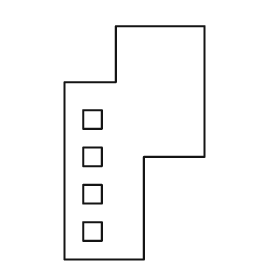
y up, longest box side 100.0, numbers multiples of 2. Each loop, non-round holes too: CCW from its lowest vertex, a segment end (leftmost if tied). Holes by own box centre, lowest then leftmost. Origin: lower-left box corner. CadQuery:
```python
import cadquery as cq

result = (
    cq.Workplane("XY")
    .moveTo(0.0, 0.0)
    .lineTo(34.0, 0.0)
    .lineTo(34.0, 44.0)
    .lineTo(60.0, 44.0)
    .lineTo(60.0, 100.0)
    .lineTo(22.0, 100.0)
    .lineTo(22.0, 76.0)
    .lineTo(0.0, 76.0)
    .close()
    .moveTo(8.0, 8.0)
    .lineTo(16.0, 8.0)
    .lineTo(16.0, 16.0)
    .lineTo(8.0, 16.0)
    .close()
    .moveTo(8.0, 24.0)
    .lineTo(16.0, 24.0)
    .lineTo(16.0, 32.0)
    .lineTo(8.0, 32.0)
    .close()
    .moveTo(8.0, 40.0)
    .lineTo(16.0, 40.0)
    .lineTo(16.0, 48.0)
    .lineTo(8.0, 48.0)
    .close()
    .moveTo(8.0, 56.0)
    .lineTo(16.0, 56.0)
    .lineTo(16.0, 64.0)
    .lineTo(8.0, 64.0)
    .close()
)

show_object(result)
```